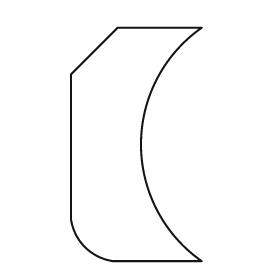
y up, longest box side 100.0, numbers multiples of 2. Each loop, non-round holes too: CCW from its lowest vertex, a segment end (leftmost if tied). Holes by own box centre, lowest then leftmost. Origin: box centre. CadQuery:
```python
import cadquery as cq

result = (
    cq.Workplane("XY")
    .moveTo(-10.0, -50.0)
    .lineTo(28.0, -50.0)
    .threePointArc((2.0, 0.0), (28.0, 50.0))
    .lineTo(-8.0, 50.0)
    .lineTo(-28.0, 30.0)
    .lineTo(-28.0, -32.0)
    .threePointArc((-22.0, -44.0), (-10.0, -50.0))
    .close()
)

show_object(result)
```